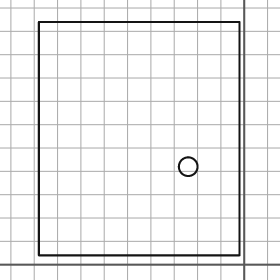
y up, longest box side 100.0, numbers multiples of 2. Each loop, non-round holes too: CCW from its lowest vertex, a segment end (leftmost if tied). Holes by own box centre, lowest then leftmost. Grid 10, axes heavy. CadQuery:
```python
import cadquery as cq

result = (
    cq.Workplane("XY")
    .moveTo(-88.0, 4.0)
    .lineTo(-2.0, 4.0)
    .lineTo(-2.0, 104.0)
    .lineTo(-88.0, 104.0)
    .close()
    .moveTo(-24.0, 42.0)
    .circle(4.0)
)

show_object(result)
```